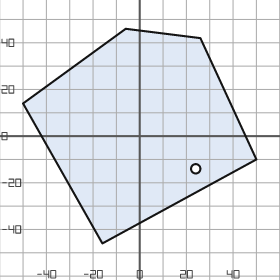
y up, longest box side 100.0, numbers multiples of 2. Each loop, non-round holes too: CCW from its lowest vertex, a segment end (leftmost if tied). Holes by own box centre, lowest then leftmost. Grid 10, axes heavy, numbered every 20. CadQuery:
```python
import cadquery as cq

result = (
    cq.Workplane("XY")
    .moveTo(-16.0, -46.0)
    .lineTo(50.0, -10.0)
    .lineTo(26.0, 42.0)
    .lineTo(-6.0, 46.0)
    .lineTo(-50.0, 14.0)
    .close()
    .moveTo(24.0, -14.0)
    .circle(2.0)
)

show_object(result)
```